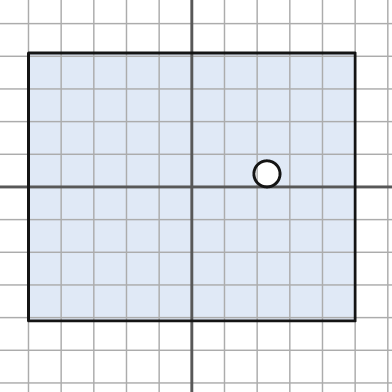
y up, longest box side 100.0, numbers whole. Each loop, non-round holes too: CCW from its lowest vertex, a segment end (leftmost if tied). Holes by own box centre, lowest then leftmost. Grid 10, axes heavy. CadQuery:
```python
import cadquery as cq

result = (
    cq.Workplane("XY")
    .moveTo(-50.0, -41.0)
    .lineTo(50.0, -41.0)
    .lineTo(50.0, 41.0)
    .lineTo(-50.0, 41.0)
    .close()
    .moveTo(23.0, 4.0)
    .circle(4.0)
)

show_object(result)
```